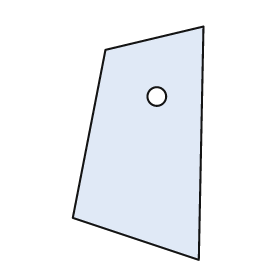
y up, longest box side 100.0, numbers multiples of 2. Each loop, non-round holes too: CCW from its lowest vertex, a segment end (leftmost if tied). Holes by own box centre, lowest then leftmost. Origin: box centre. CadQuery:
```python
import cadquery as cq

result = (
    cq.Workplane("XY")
    .moveTo(26.0, -50.0)
    .lineTo(28.0, 50.0)
    .lineTo(-14.0, 40.0)
    .lineTo(-28.0, -32.0)
    .close()
    .moveTo(8.0, 20.0)
    .circle(4.0)
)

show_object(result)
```